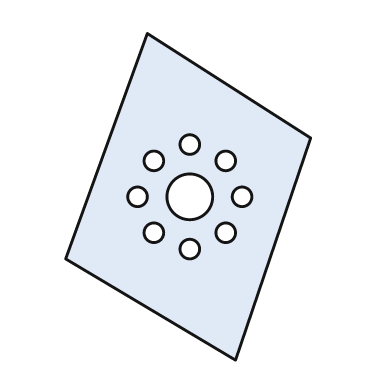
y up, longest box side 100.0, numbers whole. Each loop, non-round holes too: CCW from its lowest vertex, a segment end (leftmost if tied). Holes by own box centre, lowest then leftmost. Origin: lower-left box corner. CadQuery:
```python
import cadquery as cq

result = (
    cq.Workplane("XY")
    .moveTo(52.0, 0.0)
    .lineTo(75.0, 68.0)
    .lineTo(25.0, 100.0)
    .lineTo(0.0, 31.0)
    .close()
    .moveTo(38.0, 34.0)
    .circle(3.0)
    .moveTo(27.0, 39.0)
    .circle(3.0)
    .moveTo(49.0, 39.0)
    .circle(3.0)
    .moveTo(22.0, 50.0)
    .circle(3.0)
    .moveTo(38.0, 50.0)
    .circle(7.0)
    .moveTo(54.0, 50.0)
    .circle(3.0)
    .moveTo(27.0, 61.0)
    .circle(3.0)
    .moveTo(49.0, 61.0)
    .circle(3.0)
    .moveTo(38.0, 66.0)
    .circle(3.0)
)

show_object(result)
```